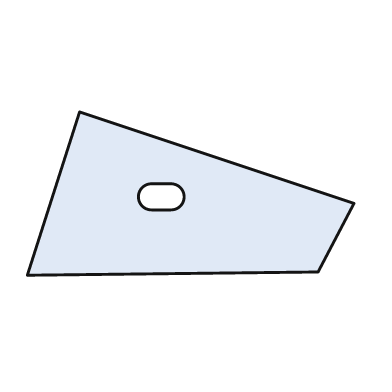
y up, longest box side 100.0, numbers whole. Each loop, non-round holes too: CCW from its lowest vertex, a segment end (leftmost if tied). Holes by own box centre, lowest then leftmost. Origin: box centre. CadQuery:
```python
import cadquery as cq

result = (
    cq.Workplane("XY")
    .moveTo(-50.0, -25.0)
    .lineTo(39.0, -24.0)
    .lineTo(50.0, -3.0)
    .lineTo(-34.0, 25.0)
    .close()
    .moveTo(-12.0, -5.0)
    .lineTo(-6.0, -5.0)
    .threePointArc((-2.0, -1.0), (-6.0, 3.0))
    .lineTo(-12.0, 3.0)
    .threePointArc((-16.0, -1.0), (-12.0, -5.0))
    .close()
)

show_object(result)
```